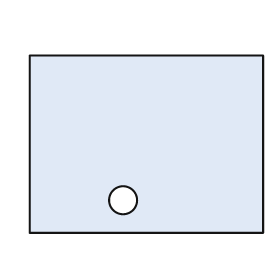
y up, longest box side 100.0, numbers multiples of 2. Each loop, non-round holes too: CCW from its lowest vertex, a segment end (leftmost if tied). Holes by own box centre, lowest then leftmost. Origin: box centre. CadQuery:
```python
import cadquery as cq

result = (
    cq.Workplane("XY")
    .moveTo(-50.0, -38.0)
    .lineTo(50.0, -38.0)
    .lineTo(50.0, 38.0)
    .lineTo(-50.0, 38.0)
    .close()
    .moveTo(-10.0, -24.0)
    .circle(6.0)
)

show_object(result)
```